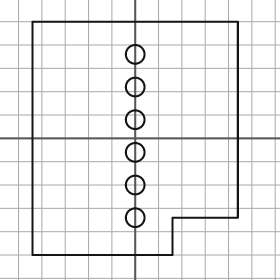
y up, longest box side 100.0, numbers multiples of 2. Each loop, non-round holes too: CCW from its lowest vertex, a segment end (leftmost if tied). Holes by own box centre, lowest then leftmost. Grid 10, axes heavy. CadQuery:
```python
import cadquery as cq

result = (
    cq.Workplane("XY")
    .moveTo(-44.0, -50.0)
    .lineTo(16.0, -50.0)
    .lineTo(16.0, -34.0)
    .lineTo(44.0, -34.0)
    .lineTo(44.0, 50.0)
    .lineTo(-44.0, 50.0)
    .close()
    .moveTo(0.0, -34.0)
    .circle(4.0)
    .moveTo(0.0, -20.0)
    .circle(4.0)
    .moveTo(0.0, -6.0)
    .circle(4.0)
    .moveTo(0.0, 8.0)
    .circle(4.0)
    .moveTo(0.0, 22.0)
    .circle(4.0)
    .moveTo(0.0, 36.0)
    .circle(4.0)
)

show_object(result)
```